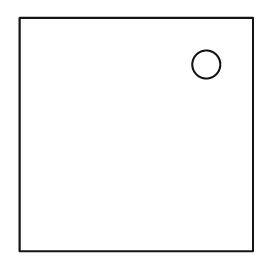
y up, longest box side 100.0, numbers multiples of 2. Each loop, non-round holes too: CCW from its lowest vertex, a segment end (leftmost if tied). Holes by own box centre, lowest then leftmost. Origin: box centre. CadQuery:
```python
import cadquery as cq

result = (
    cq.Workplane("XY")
    .moveTo(-50.0, -50.0)
    .lineTo(50.0, -50.0)
    .lineTo(50.0, 50.0)
    .lineTo(-50.0, 50.0)
    .close()
    .moveTo(30.0, 30.0)
    .circle(6.0)
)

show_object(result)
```